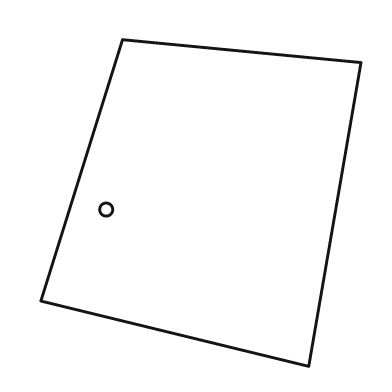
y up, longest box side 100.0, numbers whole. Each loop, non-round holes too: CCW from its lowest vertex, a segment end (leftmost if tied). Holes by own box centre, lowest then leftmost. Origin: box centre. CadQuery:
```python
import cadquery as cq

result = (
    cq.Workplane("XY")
    .moveTo(33.0, -50.0)
    .lineTo(49.0, 43.0)
    .lineTo(-24.0, 50.0)
    .lineTo(-49.0, -30.0)
    .close()
    .moveTo(-29.0, -2.0)
    .circle(2.0)
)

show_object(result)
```